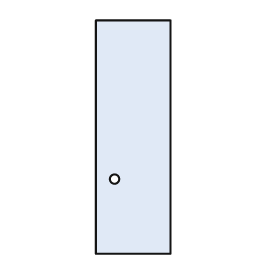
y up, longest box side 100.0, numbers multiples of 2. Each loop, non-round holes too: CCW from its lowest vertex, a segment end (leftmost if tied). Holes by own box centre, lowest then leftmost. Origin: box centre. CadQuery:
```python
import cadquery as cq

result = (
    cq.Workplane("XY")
    .moveTo(-16.0, -50.0)
    .lineTo(16.0, -50.0)
    .lineTo(16.0, 50.0)
    .lineTo(-16.0, 50.0)
    .close()
    .moveTo(-8.0, -18.0)
    .circle(2.0)
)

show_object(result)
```